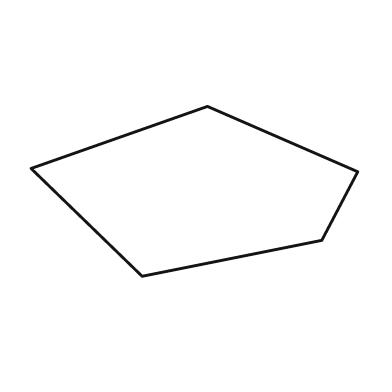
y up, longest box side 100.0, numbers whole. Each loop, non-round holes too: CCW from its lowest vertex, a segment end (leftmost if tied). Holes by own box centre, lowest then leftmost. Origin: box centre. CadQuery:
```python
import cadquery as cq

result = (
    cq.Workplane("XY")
    .moveTo(-16.0, -26.0)
    .lineTo(39.0, -15.0)
    .lineTo(50.0, 6.0)
    .lineTo(4.0, 26.0)
    .lineTo(-50.0, 7.0)
    .close()
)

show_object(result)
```